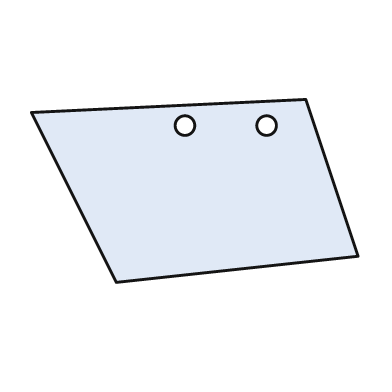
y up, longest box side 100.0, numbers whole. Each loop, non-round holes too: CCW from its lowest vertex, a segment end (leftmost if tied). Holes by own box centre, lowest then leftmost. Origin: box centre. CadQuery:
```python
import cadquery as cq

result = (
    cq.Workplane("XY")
    .moveTo(-24.0, -28.0)
    .lineTo(50.0, -20.0)
    .lineTo(34.0, 28.0)
    .lineTo(-50.0, 24.0)
    .close()
    .moveTo(-3.0, 20.0)
    .circle(3.0)
    .moveTo(22.0, 20.0)
    .circle(3.0)
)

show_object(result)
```